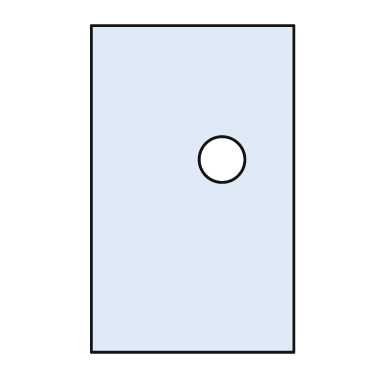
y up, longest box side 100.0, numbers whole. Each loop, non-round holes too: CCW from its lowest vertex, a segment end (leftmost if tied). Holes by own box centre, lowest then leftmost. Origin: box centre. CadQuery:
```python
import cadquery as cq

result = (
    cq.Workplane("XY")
    .moveTo(-31.0, -50.0)
    .lineTo(31.0, -50.0)
    .lineTo(31.0, 50.0)
    .lineTo(-31.0, 50.0)
    .close()
    .moveTo(9.0, 9.0)
    .circle(7.0)
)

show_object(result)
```